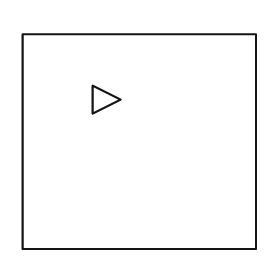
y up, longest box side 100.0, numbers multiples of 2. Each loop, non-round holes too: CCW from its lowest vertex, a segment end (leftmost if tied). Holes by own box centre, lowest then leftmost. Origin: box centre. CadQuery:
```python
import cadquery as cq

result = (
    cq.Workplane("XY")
    .moveTo(-50.0, -46.0)
    .lineTo(50.0, -46.0)
    .lineTo(50.0, 46.0)
    .lineTo(-50.0, 46.0)
    .close()
    .moveTo(-20.0, 12.0)
    .lineTo(-8.0, 18.0)
    .lineTo(-20.0, 24.0)
    .close()
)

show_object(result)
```